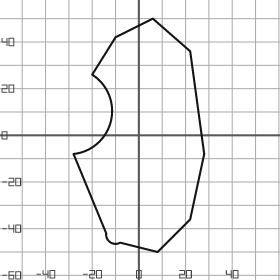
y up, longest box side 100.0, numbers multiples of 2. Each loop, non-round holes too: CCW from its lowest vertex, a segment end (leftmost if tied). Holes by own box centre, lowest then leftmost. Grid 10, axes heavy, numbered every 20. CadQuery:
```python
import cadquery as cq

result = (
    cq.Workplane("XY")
    .moveTo(8.0, -50.0)
    .lineTo(22.0, -36.0)
    .lineTo(28.0, -8.0)
    .lineTo(22.0, 36.0)
    .lineTo(6.0, 50.0)
    .lineTo(-10.0, 42.0)
    .lineTo(-20.0, 26.0)
    .threePointArc((-12.0, 6.0), (-28.0, -8.0))
    .lineTo(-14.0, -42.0)
    .threePointArc((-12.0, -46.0), (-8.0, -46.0))
    .close()
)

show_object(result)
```